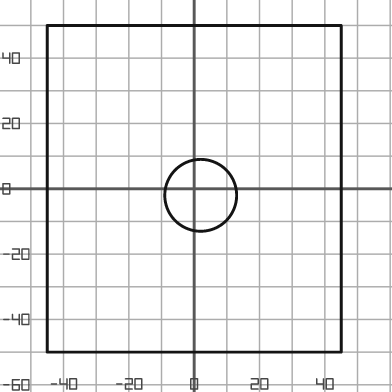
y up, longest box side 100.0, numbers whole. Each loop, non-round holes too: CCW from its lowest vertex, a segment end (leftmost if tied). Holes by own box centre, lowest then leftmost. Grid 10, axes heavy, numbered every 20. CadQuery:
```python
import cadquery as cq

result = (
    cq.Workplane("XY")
    .moveTo(-45.0, -50.0)
    .lineTo(45.0, -50.0)
    .lineTo(45.0, 50.0)
    .lineTo(-45.0, 50.0)
    .close()
    .moveTo(2.0, -2.0)
    .circle(11.0)
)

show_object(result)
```